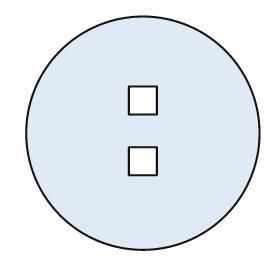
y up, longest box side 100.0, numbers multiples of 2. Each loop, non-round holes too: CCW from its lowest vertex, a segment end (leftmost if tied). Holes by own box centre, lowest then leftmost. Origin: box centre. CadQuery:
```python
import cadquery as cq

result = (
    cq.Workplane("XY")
    .moveTo(0.0, 0.0)
    .circle(50.0)
    .moveTo(-6.0, -18.0)
    .lineTo(6.0, -18.0)
    .lineTo(6.0, -6.0)
    .lineTo(-6.0, -6.0)
    .close()
    .moveTo(-6.0, 8.0)
    .lineTo(6.0, 8.0)
    .lineTo(6.0, 20.0)
    .lineTo(-6.0, 20.0)
    .close()
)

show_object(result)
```